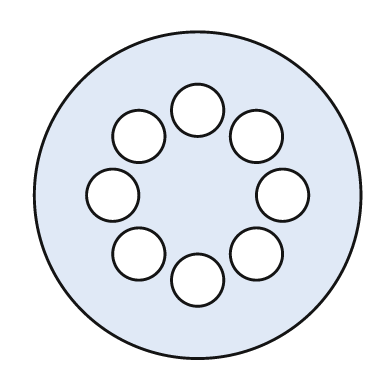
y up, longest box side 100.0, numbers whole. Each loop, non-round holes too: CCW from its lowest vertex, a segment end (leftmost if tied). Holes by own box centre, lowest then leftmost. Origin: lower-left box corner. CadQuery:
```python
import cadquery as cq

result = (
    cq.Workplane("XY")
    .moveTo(50.0, 50.0)
    .circle(50.0)
    .moveTo(50.0, 24.0)
    .circle(8.0)
    .moveTo(32.0, 32.0)
    .circle(8.0)
    .moveTo(68.0, 32.0)
    .circle(8.0)
    .moveTo(24.0, 50.0)
    .circle(8.0)
    .moveTo(76.0, 50.0)
    .circle(8.0)
    .moveTo(32.0, 68.0)
    .circle(8.0)
    .moveTo(68.0, 68.0)
    .circle(8.0)
    .moveTo(50.0, 76.0)
    .circle(8.0)
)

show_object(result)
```